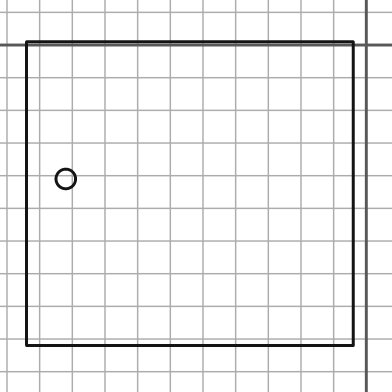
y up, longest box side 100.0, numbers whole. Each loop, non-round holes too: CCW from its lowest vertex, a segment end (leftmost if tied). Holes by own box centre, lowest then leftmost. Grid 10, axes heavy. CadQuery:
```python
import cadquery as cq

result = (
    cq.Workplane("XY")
    .moveTo(-104.0, -92.0)
    .lineTo(-4.0, -92.0)
    .lineTo(-4.0, 1.0)
    .lineTo(-104.0, 1.0)
    .close()
    .moveTo(-92.0, -41.0)
    .circle(3.0)
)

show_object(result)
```